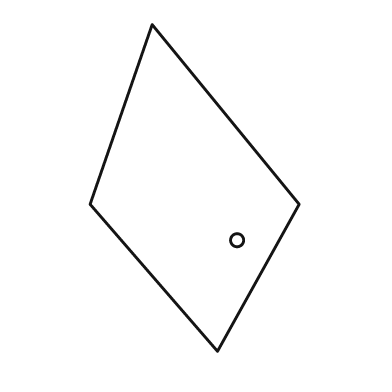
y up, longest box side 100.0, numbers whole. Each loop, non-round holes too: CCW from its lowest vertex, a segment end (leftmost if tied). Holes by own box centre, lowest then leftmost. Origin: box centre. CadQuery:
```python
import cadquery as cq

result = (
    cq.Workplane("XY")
    .moveTo(7.0, -50.0)
    .lineTo(32.0, -5.0)
    .lineTo(-13.0, 50.0)
    .lineTo(-32.0, -5.0)
    .close()
    .moveTo(13.0, -16.0)
    .circle(2.0)
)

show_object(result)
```